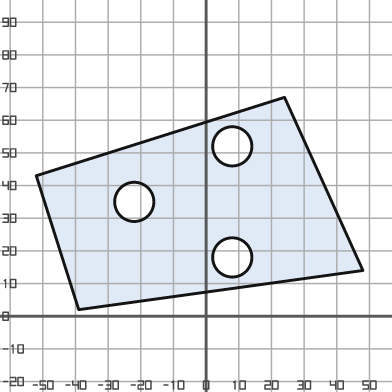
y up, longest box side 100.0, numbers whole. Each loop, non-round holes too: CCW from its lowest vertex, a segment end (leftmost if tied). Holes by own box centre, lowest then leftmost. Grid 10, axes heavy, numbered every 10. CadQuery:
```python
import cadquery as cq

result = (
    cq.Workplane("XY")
    .moveTo(-39.0, 2.0)
    .lineTo(48.0, 14.0)
    .lineTo(24.0, 67.0)
    .lineTo(-52.0, 43.0)
    .close()
    .moveTo(8.0, 18.0)
    .circle(6.0)
    .moveTo(-22.0, 35.0)
    .circle(6.0)
    .moveTo(8.0, 52.0)
    .circle(6.0)
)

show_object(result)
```